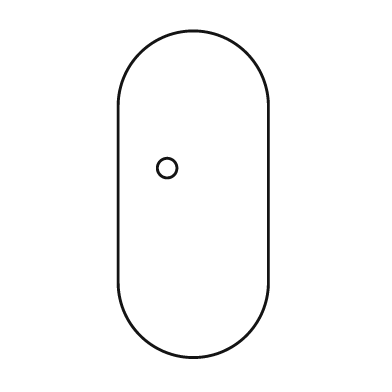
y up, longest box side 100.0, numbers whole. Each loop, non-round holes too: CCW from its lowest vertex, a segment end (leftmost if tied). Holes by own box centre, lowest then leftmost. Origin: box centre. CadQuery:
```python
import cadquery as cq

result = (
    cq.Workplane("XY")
    .moveTo(-23.0, -27.0)
    .threePointArc((0.0, -50.0), (23.0, -27.0))
    .lineTo(23.0, 27.0)
    .threePointArc((0.0, 50.0), (-23.0, 27.0))
    .close()
    .moveTo(-8.0, 8.0)
    .circle(3.0)
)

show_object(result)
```